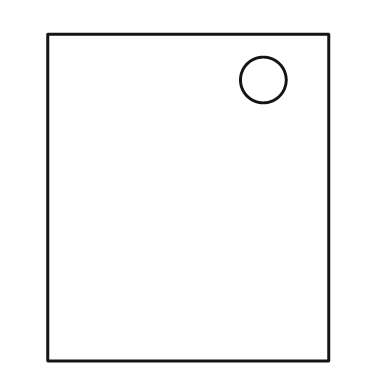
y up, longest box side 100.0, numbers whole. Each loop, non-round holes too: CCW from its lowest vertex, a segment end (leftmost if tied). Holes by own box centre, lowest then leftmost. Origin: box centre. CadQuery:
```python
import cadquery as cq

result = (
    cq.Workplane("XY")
    .moveTo(-43.0, -50.0)
    .lineTo(43.0, -50.0)
    .lineTo(43.0, 50.0)
    .lineTo(-43.0, 50.0)
    .close()
    .moveTo(23.0, 36.0)
    .circle(7.0)
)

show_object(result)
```